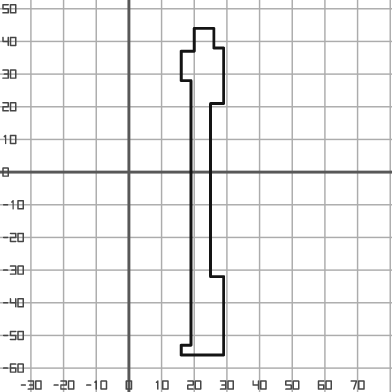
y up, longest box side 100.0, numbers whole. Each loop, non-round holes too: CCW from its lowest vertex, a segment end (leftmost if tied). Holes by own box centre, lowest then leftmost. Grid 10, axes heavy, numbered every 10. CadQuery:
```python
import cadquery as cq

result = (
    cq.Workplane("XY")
    .moveTo(16.0, -56.0)
    .lineTo(29.0, -56.0)
    .lineTo(29.0, -32.0)
    .lineTo(25.0, -32.0)
    .lineTo(25.0, 21.0)
    .lineTo(29.0, 21.0)
    .lineTo(29.0, 38.0)
    .lineTo(26.0, 38.0)
    .lineTo(26.0, 44.0)
    .lineTo(20.0, 44.0)
    .lineTo(20.0, 37.0)
    .lineTo(16.0, 37.0)
    .lineTo(16.0, 28.0)
    .lineTo(19.0, 28.0)
    .lineTo(19.0, -53.0)
    .lineTo(16.0, -53.0)
    .close()
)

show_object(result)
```